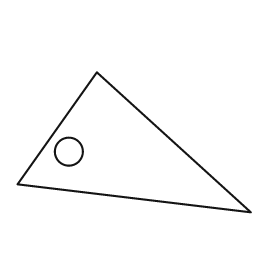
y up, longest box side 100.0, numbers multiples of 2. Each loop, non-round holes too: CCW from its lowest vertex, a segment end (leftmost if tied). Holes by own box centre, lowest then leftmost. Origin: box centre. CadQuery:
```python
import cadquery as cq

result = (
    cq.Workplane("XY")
    .moveTo(50.0, -30.0)
    .lineTo(-16.0, 30.0)
    .lineTo(-50.0, -18.0)
    .close()
    .moveTo(-28.0, -4.0)
    .circle(6.0)
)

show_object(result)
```